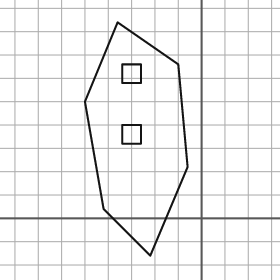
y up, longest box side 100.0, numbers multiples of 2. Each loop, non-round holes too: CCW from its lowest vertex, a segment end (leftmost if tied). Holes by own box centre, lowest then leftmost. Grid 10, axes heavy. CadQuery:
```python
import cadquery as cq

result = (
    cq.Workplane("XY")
    .moveTo(-22.0, -16.0)
    .lineTo(-6.0, 22.0)
    .lineTo(-10.0, 66.0)
    .lineTo(-36.0, 84.0)
    .lineTo(-50.0, 50.0)
    .lineTo(-42.0, 4.0)
    .close()
    .moveTo(-34.0, 32.0)
    .lineTo(-26.0, 32.0)
    .lineTo(-26.0, 40.0)
    .lineTo(-34.0, 40.0)
    .close()
    .moveTo(-34.0, 58.0)
    .lineTo(-26.0, 58.0)
    .lineTo(-26.0, 66.0)
    .lineTo(-34.0, 66.0)
    .close()
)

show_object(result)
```